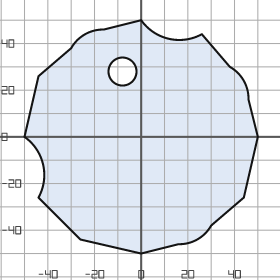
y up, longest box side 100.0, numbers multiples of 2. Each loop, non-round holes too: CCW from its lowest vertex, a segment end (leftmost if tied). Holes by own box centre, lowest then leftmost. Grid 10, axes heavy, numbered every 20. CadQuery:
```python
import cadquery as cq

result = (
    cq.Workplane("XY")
    .moveTo(0.0, -50.0)
    .lineTo(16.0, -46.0)
    .threePointArc((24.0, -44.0), (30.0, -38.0))
    .lineTo(44.0, -26.0)
    .lineTo(50.0, 0.0)
    .lineTo(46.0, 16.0)
    .threePointArc((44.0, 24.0), (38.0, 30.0))
    .lineTo(26.0, 44.0)
    .threePointArc((12.0, 42.0), (0.0, 50.0))
    .lineTo(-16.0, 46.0)
    .threePointArc((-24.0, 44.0), (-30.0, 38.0))
    .lineTo(-44.0, 26.0)
    .lineTo(-50.0, 0.0)
    .threePointArc((-42.0, -12.0), (-44.0, -26.0))
    .lineTo(-26.0, -44.0)
    .close()
    .moveTo(-8.0, 28.0)
    .circle(6.0)
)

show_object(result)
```